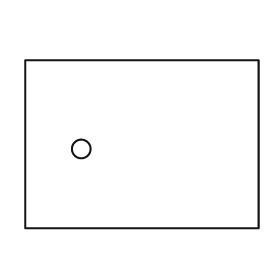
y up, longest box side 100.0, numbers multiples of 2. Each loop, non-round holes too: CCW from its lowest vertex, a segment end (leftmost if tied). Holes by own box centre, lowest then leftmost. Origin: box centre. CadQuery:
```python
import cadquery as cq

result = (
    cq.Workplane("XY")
    .moveTo(-50.0, -36.0)
    .lineTo(50.0, -36.0)
    .lineTo(50.0, 36.0)
    .lineTo(-50.0, 36.0)
    .close()
    .moveTo(-26.0, -2.0)
    .circle(4.0)
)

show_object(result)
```